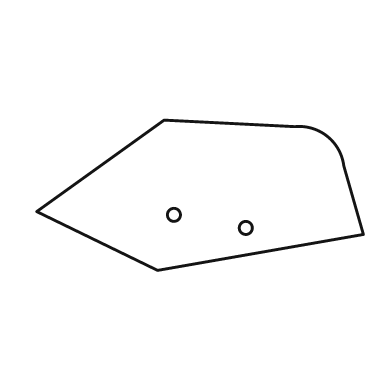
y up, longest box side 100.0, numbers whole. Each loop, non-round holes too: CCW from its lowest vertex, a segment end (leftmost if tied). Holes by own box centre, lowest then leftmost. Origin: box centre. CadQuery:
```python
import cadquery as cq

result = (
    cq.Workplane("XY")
    .moveTo(-13.0, -23.0)
    .lineTo(50.0, -12.0)
    .lineTo(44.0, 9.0)
    .threePointArc((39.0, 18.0), (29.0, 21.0))
    .lineTo(-11.0, 23.0)
    .lineTo(-50.0, -5.0)
    .close()
    .moveTo(14.0, -10.0)
    .circle(2.0)
    .moveTo(-8.0, -6.0)
    .circle(2.0)
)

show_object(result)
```